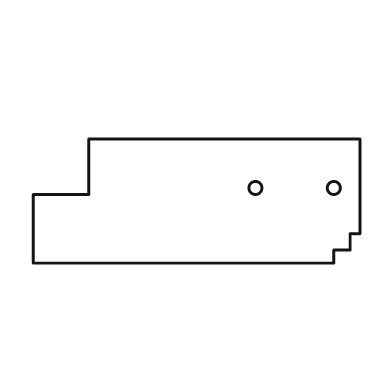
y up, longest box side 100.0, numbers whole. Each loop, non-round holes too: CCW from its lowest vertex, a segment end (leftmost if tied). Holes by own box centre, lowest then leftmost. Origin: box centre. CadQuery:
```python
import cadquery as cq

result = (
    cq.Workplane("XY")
    .moveTo(-50.0, -19.0)
    .lineTo(42.0, -19.0)
    .lineTo(42.0, -15.0)
    .lineTo(47.0, -15.0)
    .lineTo(47.0, -10.0)
    .lineTo(50.0, -10.0)
    .lineTo(50.0, 19.0)
    .lineTo(-33.0, 19.0)
    .lineTo(-33.0, 2.0)
    .lineTo(-50.0, 2.0)
    .close()
    .moveTo(18.0, 4.0)
    .circle(2.0)
    .moveTo(42.0, 4.0)
    .circle(2.0)
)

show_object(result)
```